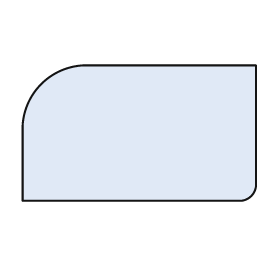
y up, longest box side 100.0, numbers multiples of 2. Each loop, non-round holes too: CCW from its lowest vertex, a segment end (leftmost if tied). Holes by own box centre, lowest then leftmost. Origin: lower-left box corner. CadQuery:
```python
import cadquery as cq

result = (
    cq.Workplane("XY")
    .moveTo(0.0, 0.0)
    .lineTo(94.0, 0.0)
    .threePointArc((98.0, 2.0), (100.0, 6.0))
    .lineTo(100.0, 58.0)
    .lineTo(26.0, 58.0)
    .threePointArc((8.0, 50.0), (0.0, 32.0))
    .close()
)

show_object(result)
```